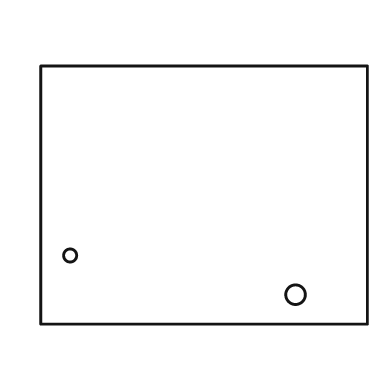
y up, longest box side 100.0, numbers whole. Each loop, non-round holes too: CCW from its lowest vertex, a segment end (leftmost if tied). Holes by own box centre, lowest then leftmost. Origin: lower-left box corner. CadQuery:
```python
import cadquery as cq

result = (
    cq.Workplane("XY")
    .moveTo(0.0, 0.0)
    .lineTo(100.0, 0.0)
    .lineTo(100.0, 79.0)
    .lineTo(0.0, 79.0)
    .close()
    .moveTo(78.0, 9.0)
    .circle(3.0)
    .moveTo(9.0, 21.0)
    .circle(2.0)
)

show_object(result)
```